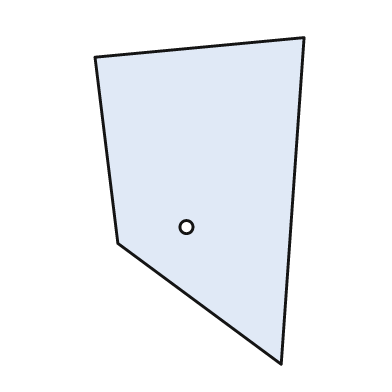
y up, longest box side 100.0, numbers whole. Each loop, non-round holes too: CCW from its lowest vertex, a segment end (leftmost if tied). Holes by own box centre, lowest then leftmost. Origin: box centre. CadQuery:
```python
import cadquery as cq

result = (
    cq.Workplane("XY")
    .moveTo(25.0, -50.0)
    .lineTo(32.0, 50.0)
    .lineTo(-32.0, 44.0)
    .lineTo(-25.0, -13.0)
    .close()
    .moveTo(-4.0, -8.0)
    .circle(2.0)
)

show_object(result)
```